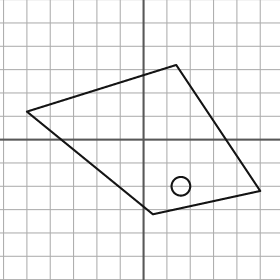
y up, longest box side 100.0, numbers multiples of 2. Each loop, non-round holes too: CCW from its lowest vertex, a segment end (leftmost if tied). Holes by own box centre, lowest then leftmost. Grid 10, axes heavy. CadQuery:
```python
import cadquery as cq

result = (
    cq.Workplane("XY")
    .moveTo(4.0, -32.0)
    .lineTo(50.0, -22.0)
    .lineTo(14.0, 32.0)
    .lineTo(-50.0, 12.0)
    .close()
    .moveTo(16.0, -20.0)
    .circle(4.0)
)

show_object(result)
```